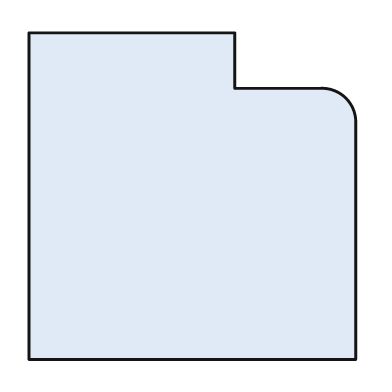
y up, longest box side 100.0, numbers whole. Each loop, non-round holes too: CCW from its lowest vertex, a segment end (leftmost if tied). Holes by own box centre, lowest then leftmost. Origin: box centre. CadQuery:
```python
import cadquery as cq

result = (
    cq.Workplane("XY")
    .moveTo(-50.0, -50.0)
    .lineTo(50.0, -50.0)
    .lineTo(50.0, 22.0)
    .threePointArc((47.0, 30.0), (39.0, 33.0))
    .lineTo(13.0, 33.0)
    .lineTo(13.0, 50.0)
    .lineTo(-50.0, 50.0)
    .close()
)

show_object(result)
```